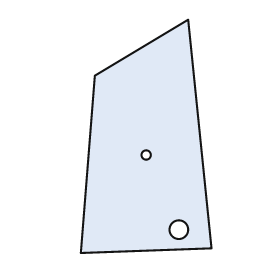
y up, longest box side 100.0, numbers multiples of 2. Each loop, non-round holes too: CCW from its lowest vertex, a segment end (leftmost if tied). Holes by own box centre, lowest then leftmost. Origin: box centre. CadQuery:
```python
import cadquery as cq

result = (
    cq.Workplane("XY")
    .moveTo(-28.0, -50.0)
    .lineTo(28.0, -48.0)
    .lineTo(18.0, 50.0)
    .lineTo(-22.0, 26.0)
    .close()
    .moveTo(14.0, -40.0)
    .circle(4.0)
    .moveTo(0.0, -8.0)
    .circle(2.0)
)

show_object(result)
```